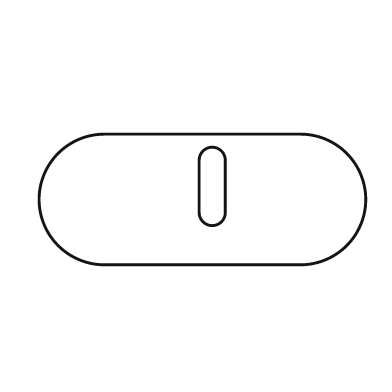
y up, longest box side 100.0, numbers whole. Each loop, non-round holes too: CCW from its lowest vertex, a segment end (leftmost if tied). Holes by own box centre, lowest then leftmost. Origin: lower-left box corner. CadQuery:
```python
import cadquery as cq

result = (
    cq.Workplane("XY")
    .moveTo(20.0, 0.0)
    .lineTo(80.0, 0.0)
    .threePointArc((100.0, 20.0), (80.0, 40.0))
    .lineTo(20.0, 40.0)
    .threePointArc((0.0, 20.0), (20.0, 0.0))
    .close()
    .moveTo(49.0, 16.0)
    .threePointArc((53.0, 12.0), (57.0, 16.0))
    .lineTo(57.0, 32.0)
    .threePointArc((53.0, 36.0), (49.0, 32.0))
    .close()
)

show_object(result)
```